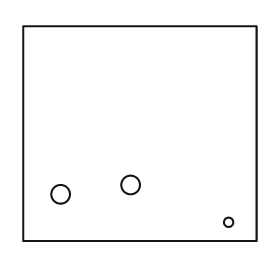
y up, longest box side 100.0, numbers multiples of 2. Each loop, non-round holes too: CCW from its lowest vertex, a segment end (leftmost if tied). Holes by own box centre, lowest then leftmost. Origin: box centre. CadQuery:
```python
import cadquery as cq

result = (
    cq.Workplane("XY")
    .moveTo(-50.0, -46.0)
    .lineTo(50.0, -46.0)
    .lineTo(50.0, 46.0)
    .lineTo(-50.0, 46.0)
    .close()
    .moveTo(38.0, -38.0)
    .circle(2.0)
    .moveTo(-34.0, -26.0)
    .circle(4.0)
    .moveTo(-4.0, -22.0)
    .circle(4.0)
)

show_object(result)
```